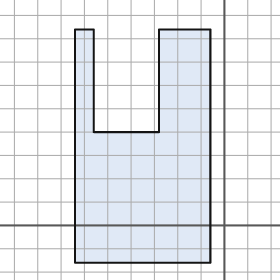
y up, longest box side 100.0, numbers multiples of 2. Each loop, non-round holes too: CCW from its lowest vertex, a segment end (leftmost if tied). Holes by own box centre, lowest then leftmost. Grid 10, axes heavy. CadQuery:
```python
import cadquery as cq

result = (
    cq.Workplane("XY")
    .moveTo(-64.0, -16.0)
    .lineTo(-6.0, -16.0)
    .lineTo(-6.0, 84.0)
    .lineTo(-28.0, 84.0)
    .lineTo(-28.0, 40.0)
    .lineTo(-56.0, 40.0)
    .lineTo(-56.0, 84.0)
    .lineTo(-64.0, 84.0)
    .close()
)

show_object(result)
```